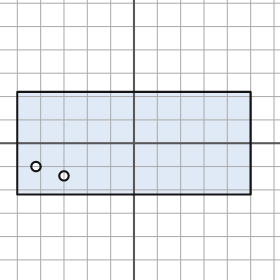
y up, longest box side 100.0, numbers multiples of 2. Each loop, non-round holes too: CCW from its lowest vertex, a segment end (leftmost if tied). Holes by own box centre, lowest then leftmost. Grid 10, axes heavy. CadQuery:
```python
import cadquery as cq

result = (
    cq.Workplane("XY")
    .moveTo(-50.0, -22.0)
    .lineTo(50.0, -22.0)
    .lineTo(50.0, 22.0)
    .lineTo(-50.0, 22.0)
    .close()
    .moveTo(-30.0, -14.0)
    .circle(2.0)
    .moveTo(-42.0, -10.0)
    .circle(2.0)
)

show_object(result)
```